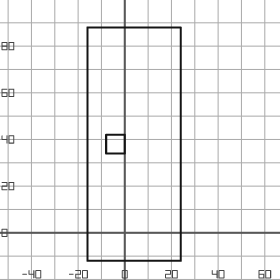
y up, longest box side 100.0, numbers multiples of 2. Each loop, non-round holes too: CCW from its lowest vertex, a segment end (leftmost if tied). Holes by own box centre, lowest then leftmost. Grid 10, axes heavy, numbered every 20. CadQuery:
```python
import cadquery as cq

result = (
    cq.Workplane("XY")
    .moveTo(-16.0, -12.0)
    .lineTo(24.0, -12.0)
    .lineTo(24.0, 88.0)
    .lineTo(-16.0, 88.0)
    .close()
    .moveTo(-8.0, 34.0)
    .lineTo(0.0, 34.0)
    .lineTo(0.0, 42.0)
    .lineTo(-8.0, 42.0)
    .close()
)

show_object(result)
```